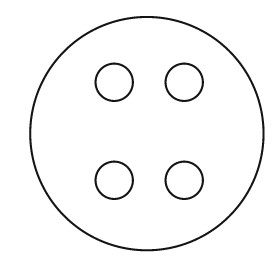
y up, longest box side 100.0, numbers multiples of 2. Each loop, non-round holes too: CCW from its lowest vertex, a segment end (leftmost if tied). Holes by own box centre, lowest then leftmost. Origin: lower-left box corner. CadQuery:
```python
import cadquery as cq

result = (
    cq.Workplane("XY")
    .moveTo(50.0, 50.0)
    .circle(50.0)
    .moveTo(36.0, 30.0)
    .circle(8.0)
    .moveTo(66.0, 30.0)
    .circle(8.0)
    .moveTo(36.0, 72.0)
    .circle(8.0)
    .moveTo(66.0, 72.0)
    .circle(8.0)
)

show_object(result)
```